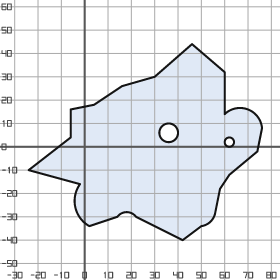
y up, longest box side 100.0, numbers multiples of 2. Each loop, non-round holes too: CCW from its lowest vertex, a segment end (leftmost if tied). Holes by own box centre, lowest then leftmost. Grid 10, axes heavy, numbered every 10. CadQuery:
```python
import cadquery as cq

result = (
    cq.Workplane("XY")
    .moveTo(42.0, -40.0)
    .lineTo(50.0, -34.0)
    .threePointArc((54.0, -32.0), (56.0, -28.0))
    .lineTo(58.0, -18.0)
    .lineTo(62.0, -12.0)
    .lineTo(74.0, -2.0)
    .lineTo(76.0, 8.0)
    .threePointArc((70.0, 16.0), (60.0, 14.0))
    .lineTo(60.0, 32.0)
    .lineTo(46.0, 44.0)
    .lineTo(30.0, 30.0)
    .lineTo(16.0, 26.0)
    .lineTo(4.0, 18.0)
    .lineTo(-6.0, 16.0)
    .lineTo(-6.0, 4.0)
    .lineTo(-24.0, -10.0)
    .lineTo(-2.0, -16.0)
    .threePointArc((-4.0, -26.0), (2.0, -34.0))
    .lineTo(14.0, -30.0)
    .threePointArc((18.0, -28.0), (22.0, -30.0))
    .close()
    .moveTo(62.0, 2.0)
    .circle(2.0)
    .moveTo(36.0, 6.0)
    .circle(4.0)
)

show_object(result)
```